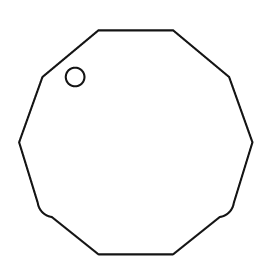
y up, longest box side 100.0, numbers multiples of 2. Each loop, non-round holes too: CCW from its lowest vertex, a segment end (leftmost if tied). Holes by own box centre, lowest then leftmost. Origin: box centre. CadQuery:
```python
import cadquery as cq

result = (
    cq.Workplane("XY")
    .moveTo(-16.0, -48.0)
    .lineTo(16.0, -48.0)
    .lineTo(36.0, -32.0)
    .threePointArc((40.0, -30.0), (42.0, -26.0))
    .lineTo(50.0, 0.0)
    .lineTo(40.0, 28.0)
    .lineTo(16.0, 48.0)
    .lineTo(-16.0, 48.0)
    .lineTo(-40.0, 28.0)
    .lineTo(-50.0, 0.0)
    .lineTo(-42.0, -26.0)
    .threePointArc((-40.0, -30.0), (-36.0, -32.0))
    .close()
    .moveTo(-26.0, 28.0)
    .circle(4.0)
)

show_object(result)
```